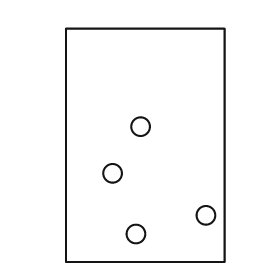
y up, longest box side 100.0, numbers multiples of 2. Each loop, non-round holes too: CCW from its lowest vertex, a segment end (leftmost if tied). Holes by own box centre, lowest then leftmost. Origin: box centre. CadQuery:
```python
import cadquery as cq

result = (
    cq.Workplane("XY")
    .moveTo(-34.0, -50.0)
    .lineTo(34.0, -50.0)
    .lineTo(34.0, 50.0)
    .lineTo(-34.0, 50.0)
    .close()
    .moveTo(-4.0, -38.0)
    .circle(4.0)
    .moveTo(26.0, -30.0)
    .circle(4.0)
    .moveTo(-14.0, -12.0)
    .circle(4.0)
    .moveTo(-2.0, 8.0)
    .circle(4.0)
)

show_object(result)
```